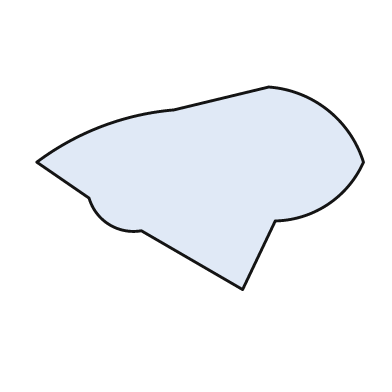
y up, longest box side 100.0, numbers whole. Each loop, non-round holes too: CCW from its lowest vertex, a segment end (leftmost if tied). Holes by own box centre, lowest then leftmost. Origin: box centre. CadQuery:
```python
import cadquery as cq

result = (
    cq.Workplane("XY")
    .moveTo(13.0, -31.0)
    .lineTo(23.0, -10.0)
    .threePointArc((39.0, -5.0), (50.0, 8.0))
    .threePointArc((39.0, 24.0), (21.0, 31.0))
    .lineTo(-8.0, 24.0)
    .threePointArc((-30.0, 19.0), (-50.0, 8.0))
    .lineTo(-34.0, -3.0)
    .threePointArc((-28.0, -11.0), (-18.0, -13.0))
    .close()
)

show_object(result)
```